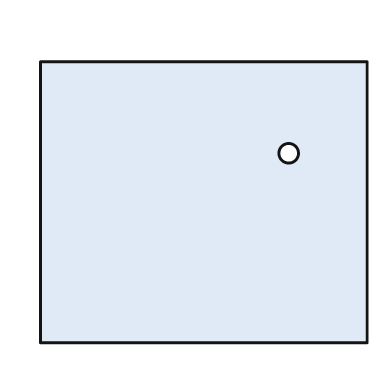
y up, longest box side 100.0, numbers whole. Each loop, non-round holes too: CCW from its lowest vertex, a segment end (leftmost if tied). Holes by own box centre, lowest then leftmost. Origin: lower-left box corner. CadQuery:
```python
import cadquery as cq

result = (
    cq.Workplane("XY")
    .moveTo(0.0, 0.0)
    .lineTo(100.0, 0.0)
    .lineTo(100.0, 86.0)
    .lineTo(0.0, 86.0)
    .close()
    .moveTo(76.0, 58.0)
    .circle(3.0)
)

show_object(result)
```